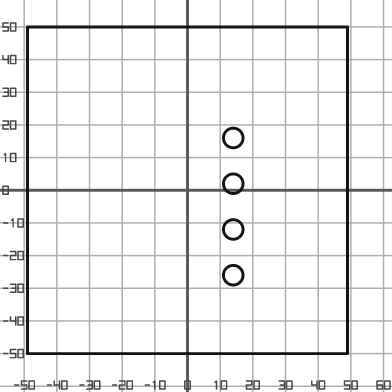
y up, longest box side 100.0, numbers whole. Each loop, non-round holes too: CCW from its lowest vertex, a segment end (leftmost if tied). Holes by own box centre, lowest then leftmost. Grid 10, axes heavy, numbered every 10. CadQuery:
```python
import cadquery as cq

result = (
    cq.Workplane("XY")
    .moveTo(-49.0, -50.0)
    .lineTo(49.0, -50.0)
    .lineTo(49.0, 50.0)
    .lineTo(-49.0, 50.0)
    .close()
    .moveTo(14.0, -26.0)
    .circle(3.0)
    .moveTo(14.0, -12.0)
    .circle(3.0)
    .moveTo(14.0, 2.0)
    .circle(3.0)
    .moveTo(14.0, 16.0)
    .circle(3.0)
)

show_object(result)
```